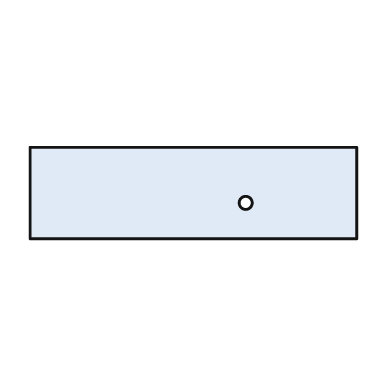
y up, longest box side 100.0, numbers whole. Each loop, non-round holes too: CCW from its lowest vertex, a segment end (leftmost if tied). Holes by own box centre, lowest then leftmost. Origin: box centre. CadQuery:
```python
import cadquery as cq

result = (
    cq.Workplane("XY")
    .moveTo(-50.0, -14.0)
    .lineTo(50.0, -14.0)
    .lineTo(50.0, 14.0)
    .lineTo(-50.0, 14.0)
    .close()
    .moveTo(16.0, -3.0)
    .circle(2.0)
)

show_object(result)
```